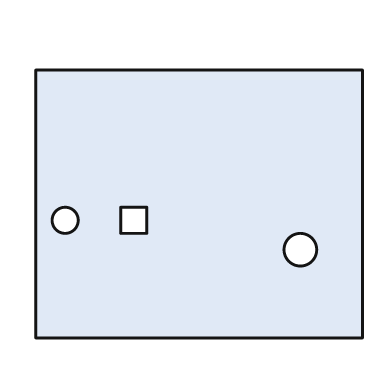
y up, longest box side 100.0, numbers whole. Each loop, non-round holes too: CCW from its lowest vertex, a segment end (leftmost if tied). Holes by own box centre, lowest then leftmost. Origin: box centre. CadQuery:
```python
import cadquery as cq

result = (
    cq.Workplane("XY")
    .moveTo(-50.0, -41.0)
    .lineTo(50.0, -41.0)
    .lineTo(50.0, 41.0)
    .lineTo(-50.0, 41.0)
    .close()
    .moveTo(31.0, -14.0)
    .circle(5.0)
    .moveTo(-41.0, -5.0)
    .circle(4.0)
    .moveTo(-24.0, -9.0)
    .lineTo(-16.0, -9.0)
    .lineTo(-16.0, -1.0)
    .lineTo(-24.0, -1.0)
    .close()
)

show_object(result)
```